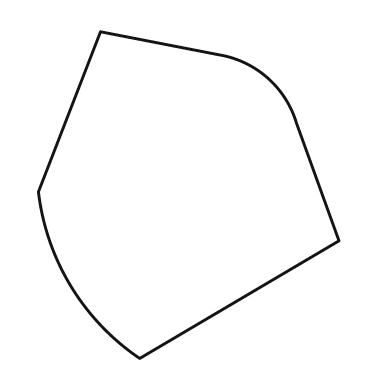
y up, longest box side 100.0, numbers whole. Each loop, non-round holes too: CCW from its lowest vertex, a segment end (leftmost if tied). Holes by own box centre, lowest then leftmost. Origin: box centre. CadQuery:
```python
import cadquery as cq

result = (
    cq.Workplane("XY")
    .moveTo(-15.0, -50.0)
    .lineTo(46.0, -14.0)
    .lineTo(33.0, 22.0)
    .threePointArc((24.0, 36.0), (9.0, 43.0))
    .lineTo(-27.0, 50.0)
    .lineTo(-46.0, 1.0)
    .threePointArc((-36.0, -28.0), (-15.0, -50.0))
    .close()
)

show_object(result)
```